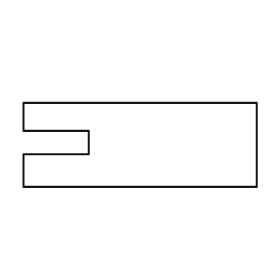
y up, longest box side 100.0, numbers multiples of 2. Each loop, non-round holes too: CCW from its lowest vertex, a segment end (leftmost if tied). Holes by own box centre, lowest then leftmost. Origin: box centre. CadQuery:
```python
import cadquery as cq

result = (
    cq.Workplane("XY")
    .moveTo(-50.0, -18.0)
    .lineTo(50.0, -18.0)
    .lineTo(50.0, 18.0)
    .lineTo(-50.0, 18.0)
    .lineTo(-50.0, 6.0)
    .lineTo(-22.0, 6.0)
    .lineTo(-22.0, -4.0)
    .lineTo(-50.0, -4.0)
    .close()
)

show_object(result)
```